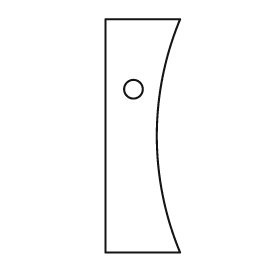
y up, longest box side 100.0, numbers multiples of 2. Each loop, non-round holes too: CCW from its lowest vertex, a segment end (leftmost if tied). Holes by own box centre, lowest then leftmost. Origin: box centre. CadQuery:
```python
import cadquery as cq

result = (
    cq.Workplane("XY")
    .moveTo(-16.0, -50.0)
    .lineTo(16.0, -50.0)
    .threePointArc((6.0, 0.0), (16.0, 50.0))
    .lineTo(-16.0, 50.0)
    .close()
    .moveTo(-4.0, 20.0)
    .circle(4.0)
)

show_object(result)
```